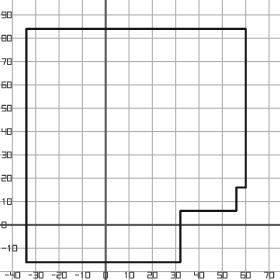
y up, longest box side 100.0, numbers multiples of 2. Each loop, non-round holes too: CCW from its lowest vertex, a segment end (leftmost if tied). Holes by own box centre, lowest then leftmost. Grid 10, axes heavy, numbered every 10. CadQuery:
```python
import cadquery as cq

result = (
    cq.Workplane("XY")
    .moveTo(-34.0, -16.0)
    .lineTo(32.0, -16.0)
    .lineTo(32.0, 6.0)
    .lineTo(56.0, 6.0)
    .lineTo(56.0, 16.0)
    .lineTo(60.0, 16.0)
    .lineTo(60.0, 84.0)
    .lineTo(-34.0, 84.0)
    .close()
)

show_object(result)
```